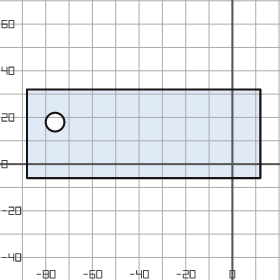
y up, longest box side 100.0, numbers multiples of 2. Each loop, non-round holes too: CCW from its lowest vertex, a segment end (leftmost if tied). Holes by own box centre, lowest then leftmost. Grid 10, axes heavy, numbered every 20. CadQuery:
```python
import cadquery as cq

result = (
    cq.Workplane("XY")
    .moveTo(-88.0, -6.0)
    .lineTo(12.0, -6.0)
    .lineTo(12.0, 32.0)
    .lineTo(-88.0, 32.0)
    .close()
    .moveTo(-76.0, 18.0)
    .circle(4.0)
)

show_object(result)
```